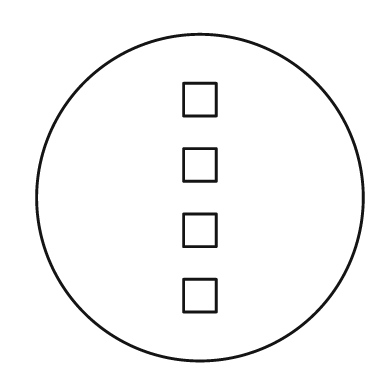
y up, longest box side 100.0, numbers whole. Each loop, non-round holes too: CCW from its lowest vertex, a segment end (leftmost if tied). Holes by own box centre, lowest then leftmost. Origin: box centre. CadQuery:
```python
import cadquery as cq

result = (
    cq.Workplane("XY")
    .moveTo(0.0, 0.0)
    .circle(50.0)
    .moveTo(-5.0, -35.0)
    .lineTo(5.0, -35.0)
    .lineTo(5.0, -25.0)
    .lineTo(-5.0, -25.0)
    .close()
    .moveTo(-5.0, -15.0)
    .lineTo(5.0, -15.0)
    .lineTo(5.0, -5.0)
    .lineTo(-5.0, -5.0)
    .close()
    .moveTo(-5.0, 5.0)
    .lineTo(5.0, 5.0)
    .lineTo(5.0, 15.0)
    .lineTo(-5.0, 15.0)
    .close()
    .moveTo(-5.0, 25.0)
    .lineTo(5.0, 25.0)
    .lineTo(5.0, 35.0)
    .lineTo(-5.0, 35.0)
    .close()
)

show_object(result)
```